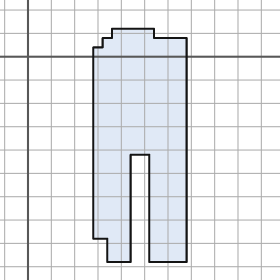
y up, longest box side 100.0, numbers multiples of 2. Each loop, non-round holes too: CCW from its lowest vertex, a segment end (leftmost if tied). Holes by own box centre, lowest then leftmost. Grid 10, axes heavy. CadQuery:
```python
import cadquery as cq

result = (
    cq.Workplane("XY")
    .moveTo(34.0, -88.0)
    .lineTo(44.0, -88.0)
    .lineTo(44.0, -42.0)
    .lineTo(52.0, -42.0)
    .lineTo(52.0, -88.0)
    .lineTo(68.0, -88.0)
    .lineTo(68.0, 8.0)
    .lineTo(54.0, 8.0)
    .lineTo(54.0, 12.0)
    .lineTo(36.0, 12.0)
    .lineTo(36.0, 8.0)
    .lineTo(32.0, 8.0)
    .lineTo(32.0, 4.0)
    .lineTo(28.0, 4.0)
    .lineTo(28.0, -78.0)
    .lineTo(34.0, -78.0)
    .close()
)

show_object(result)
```